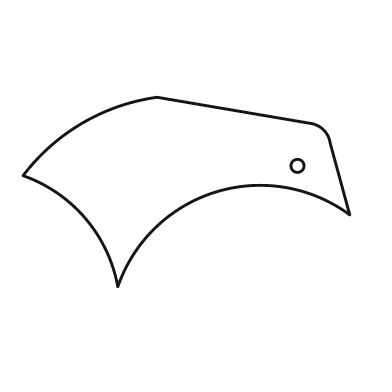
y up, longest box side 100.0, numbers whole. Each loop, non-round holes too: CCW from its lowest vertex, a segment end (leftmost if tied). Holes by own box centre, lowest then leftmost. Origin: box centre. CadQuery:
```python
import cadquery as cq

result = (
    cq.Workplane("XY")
    .moveTo(-21.0, -29.0)
    .threePointArc((9.0, 0.0), (50.0, -7.0))
    .lineTo(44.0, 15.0)
    .threePointArc((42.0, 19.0), (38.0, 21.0))
    .lineTo(-9.0, 29.0)
    .threePointArc((-32.0, 21.0), (-50.0, 5.0))
    .threePointArc((-31.0, -8.0), (-21.0, -29.0))
    .close()
    .moveTo(34.0, 8.0)
    .circle(2.0)
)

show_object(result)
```